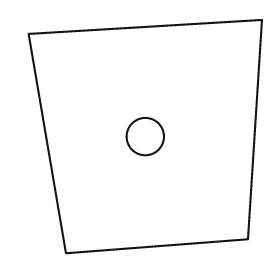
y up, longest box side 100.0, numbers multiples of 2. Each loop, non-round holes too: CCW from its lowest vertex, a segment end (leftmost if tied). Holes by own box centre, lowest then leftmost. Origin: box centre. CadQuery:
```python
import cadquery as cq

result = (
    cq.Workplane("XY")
    .moveTo(-34.0, -50.0)
    .lineTo(44.0, -44.0)
    .lineTo(50.0, 50.0)
    .lineTo(-50.0, 44.0)
    .close()
    .moveTo(0.0, 0.0)
    .circle(8.0)
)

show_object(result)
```